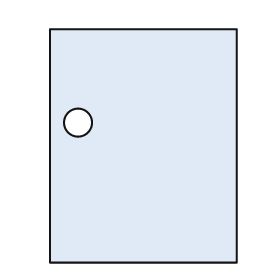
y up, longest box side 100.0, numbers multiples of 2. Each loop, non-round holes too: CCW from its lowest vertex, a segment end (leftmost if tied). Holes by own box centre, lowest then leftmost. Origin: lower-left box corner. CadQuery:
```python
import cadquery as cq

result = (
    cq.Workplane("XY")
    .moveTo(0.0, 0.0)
    .lineTo(80.0, 0.0)
    .lineTo(80.0, 100.0)
    .lineTo(0.0, 100.0)
    .close()
    .moveTo(12.0, 60.0)
    .circle(6.0)
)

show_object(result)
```